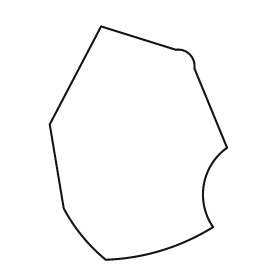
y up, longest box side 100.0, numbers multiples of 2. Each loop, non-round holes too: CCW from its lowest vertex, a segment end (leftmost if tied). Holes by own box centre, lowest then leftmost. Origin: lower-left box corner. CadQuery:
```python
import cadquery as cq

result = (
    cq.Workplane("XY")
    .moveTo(24.0, 0.0)
    .threePointArc((48.0, 4.0), (70.0, 14.0))
    .threePointArc((66.0, 32.0), (76.0, 48.0))
    .lineTo(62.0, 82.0)
    .threePointArc((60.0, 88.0), (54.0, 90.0))
    .lineTo(22.0, 100.0)
    .lineTo(0.0, 58.0)
    .lineTo(6.0, 22.0)
    .threePointArc((14.0, 10.0), (24.0, 0.0))
    .close()
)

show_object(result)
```